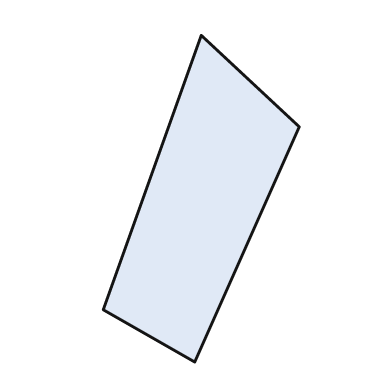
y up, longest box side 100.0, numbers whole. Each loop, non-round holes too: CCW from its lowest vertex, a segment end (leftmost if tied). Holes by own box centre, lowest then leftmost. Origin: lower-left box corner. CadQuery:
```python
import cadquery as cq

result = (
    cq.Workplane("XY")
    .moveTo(28.0, 0.0)
    .lineTo(60.0, 72.0)
    .lineTo(30.0, 100.0)
    .lineTo(0.0, 16.0)
    .close()
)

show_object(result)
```